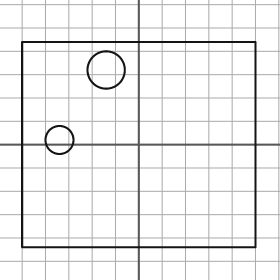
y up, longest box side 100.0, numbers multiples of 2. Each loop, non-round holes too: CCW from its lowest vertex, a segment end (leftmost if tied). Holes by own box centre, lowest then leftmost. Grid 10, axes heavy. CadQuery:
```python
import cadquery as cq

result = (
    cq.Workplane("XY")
    .moveTo(-50.0, -44.0)
    .lineTo(50.0, -44.0)
    .lineTo(50.0, 44.0)
    .lineTo(-50.0, 44.0)
    .close()
    .moveTo(-34.0, 2.0)
    .circle(6.0)
    .moveTo(-14.0, 32.0)
    .circle(8.0)
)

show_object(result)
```